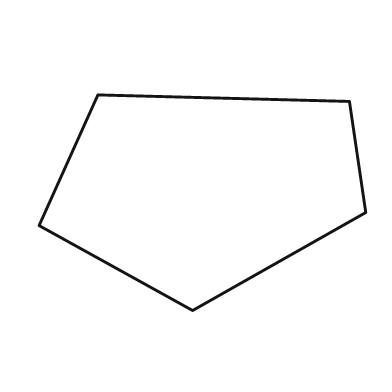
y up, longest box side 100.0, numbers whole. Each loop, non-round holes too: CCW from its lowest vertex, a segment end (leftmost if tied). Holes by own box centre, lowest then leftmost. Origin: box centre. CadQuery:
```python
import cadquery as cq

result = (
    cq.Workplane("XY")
    .moveTo(-3.0, -33.0)
    .lineTo(50.0, -3.0)
    .lineTo(45.0, 31.0)
    .lineTo(-32.0, 33.0)
    .lineTo(-50.0, -7.0)
    .close()
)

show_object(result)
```